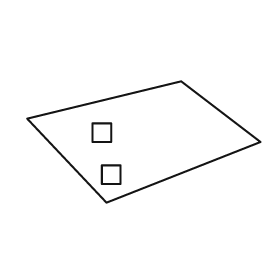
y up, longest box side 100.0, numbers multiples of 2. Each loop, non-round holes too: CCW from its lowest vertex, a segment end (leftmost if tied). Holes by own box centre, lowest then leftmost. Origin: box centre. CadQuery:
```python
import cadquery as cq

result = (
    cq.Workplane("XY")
    .moveTo(-16.0, -26.0)
    .lineTo(50.0, 0.0)
    .lineTo(16.0, 26.0)
    .lineTo(-50.0, 10.0)
    .close()
    .moveTo(-18.0, -18.0)
    .lineTo(-10.0, -18.0)
    .lineTo(-10.0, -10.0)
    .lineTo(-18.0, -10.0)
    .close()
    .moveTo(-22.0, 0.0)
    .lineTo(-14.0, 0.0)
    .lineTo(-14.0, 8.0)
    .lineTo(-22.0, 8.0)
    .close()
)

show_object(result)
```